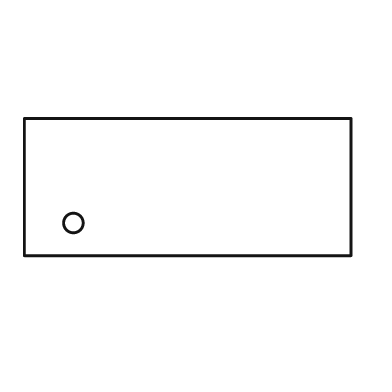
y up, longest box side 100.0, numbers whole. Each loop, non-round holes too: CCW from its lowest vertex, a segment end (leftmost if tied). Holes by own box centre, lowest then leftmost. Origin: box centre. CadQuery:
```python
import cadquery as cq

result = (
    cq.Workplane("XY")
    .moveTo(-50.0, -21.0)
    .lineTo(50.0, -21.0)
    .lineTo(50.0, 21.0)
    .lineTo(-50.0, 21.0)
    .close()
    .moveTo(-35.0, -11.0)
    .circle(3.0)
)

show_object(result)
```